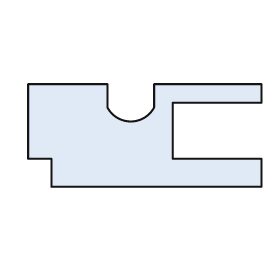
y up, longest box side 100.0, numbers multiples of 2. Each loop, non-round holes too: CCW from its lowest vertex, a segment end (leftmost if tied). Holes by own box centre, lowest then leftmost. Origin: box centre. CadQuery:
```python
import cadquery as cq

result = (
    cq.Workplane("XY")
    .moveTo(-40.0, -22.0)
    .lineTo(50.0, -22.0)
    .lineTo(50.0, -10.0)
    .lineTo(12.0, -10.0)
    .lineTo(12.0, 14.0)
    .lineTo(50.0, 14.0)
    .lineTo(50.0, 22.0)
    .lineTo(4.0, 22.0)
    .lineTo(4.0, 12.0)
    .threePointArc((-6.0, 6.0), (-16.0, 12.0))
    .lineTo(-16.0, 22.0)
    .lineTo(-50.0, 22.0)
    .lineTo(-50.0, -10.0)
    .lineTo(-40.0, -10.0)
    .close()
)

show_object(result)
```